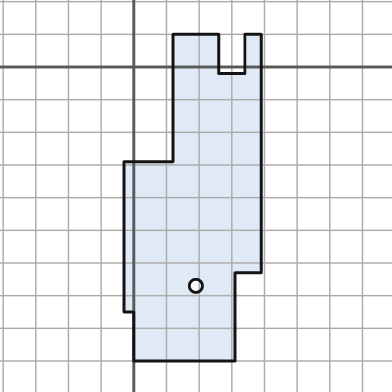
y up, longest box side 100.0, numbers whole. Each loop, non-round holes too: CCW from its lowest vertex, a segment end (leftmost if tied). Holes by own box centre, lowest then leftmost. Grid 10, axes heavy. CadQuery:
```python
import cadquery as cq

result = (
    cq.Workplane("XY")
    .moveTo(0.0, -90.0)
    .lineTo(31.0, -90.0)
    .lineTo(31.0, -63.0)
    .lineTo(39.0, -63.0)
    .lineTo(39.0, 10.0)
    .lineTo(34.0, 10.0)
    .lineTo(34.0, -2.0)
    .lineTo(26.0, -2.0)
    .lineTo(26.0, 10.0)
    .lineTo(12.0, 10.0)
    .lineTo(12.0, -29.0)
    .lineTo(-3.0, -29.0)
    .lineTo(-3.0, -75.0)
    .lineTo(0.0, -75.0)
    .close()
    .moveTo(19.0, -67.0)
    .circle(2.0)
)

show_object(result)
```